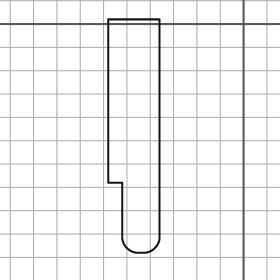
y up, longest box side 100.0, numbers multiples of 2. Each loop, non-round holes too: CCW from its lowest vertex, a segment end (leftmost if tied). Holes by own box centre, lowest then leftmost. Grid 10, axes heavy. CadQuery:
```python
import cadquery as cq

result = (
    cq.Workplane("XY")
    .moveTo(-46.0, -98.0)
    .lineTo(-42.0, -98.0)
    .threePointArc((-38.0, -96.0), (-36.0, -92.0))
    .lineTo(-36.0, 2.0)
    .lineTo(-58.0, 2.0)
    .lineTo(-58.0, -68.0)
    .lineTo(-52.0, -68.0)
    .lineTo(-52.0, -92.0)
    .threePointArc((-50.0, -96.0), (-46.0, -98.0))
    .close()
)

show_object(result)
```